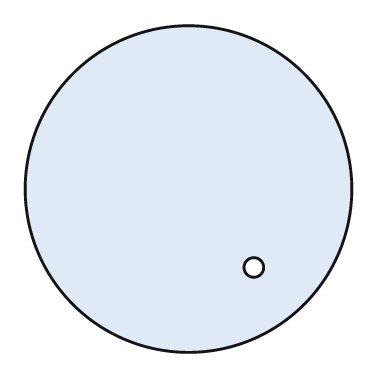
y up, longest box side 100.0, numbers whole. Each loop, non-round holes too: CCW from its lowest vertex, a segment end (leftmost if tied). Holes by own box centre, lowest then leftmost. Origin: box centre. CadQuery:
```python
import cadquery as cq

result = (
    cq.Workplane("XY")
    .moveTo(0.0, 0.0)
    .circle(50.0)
    .moveTo(20.0, -24.0)
    .circle(3.0)
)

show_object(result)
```